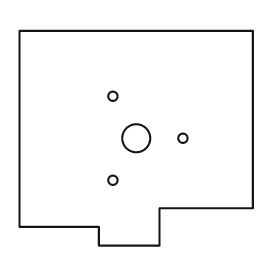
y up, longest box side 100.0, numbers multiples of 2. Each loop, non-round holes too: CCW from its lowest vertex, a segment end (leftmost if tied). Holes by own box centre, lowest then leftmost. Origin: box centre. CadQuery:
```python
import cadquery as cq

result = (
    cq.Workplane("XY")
    .moveTo(-16.0, -46.0)
    .lineTo(10.0, -46.0)
    .lineTo(10.0, -30.0)
    .lineTo(50.0, -30.0)
    .lineTo(50.0, 46.0)
    .lineTo(-50.0, 46.0)
    .lineTo(-50.0, -38.0)
    .lineTo(-16.0, -38.0)
    .close()
    .moveTo(-10.0, -18.0)
    .circle(2.0)
    .moveTo(0.0, 0.0)
    .circle(6.0)
    .moveTo(20.0, 0.0)
    .circle(2.0)
    .moveTo(-10.0, 18.0)
    .circle(2.0)
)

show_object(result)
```